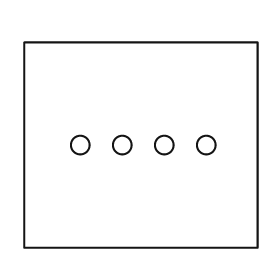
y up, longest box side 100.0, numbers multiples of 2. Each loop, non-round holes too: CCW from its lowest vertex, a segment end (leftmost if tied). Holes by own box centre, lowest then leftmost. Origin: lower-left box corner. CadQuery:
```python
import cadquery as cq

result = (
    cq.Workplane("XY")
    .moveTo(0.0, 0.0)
    .lineTo(100.0, 0.0)
    .lineTo(100.0, 88.0)
    .lineTo(0.0, 88.0)
    .close()
    .moveTo(24.0, 44.0)
    .circle(4.0)
    .moveTo(42.0, 44.0)
    .circle(4.0)
    .moveTo(60.0, 44.0)
    .circle(4.0)
    .moveTo(78.0, 44.0)
    .circle(4.0)
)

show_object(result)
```